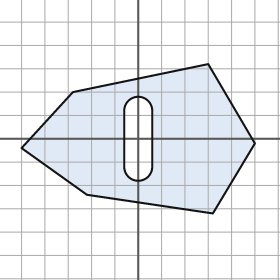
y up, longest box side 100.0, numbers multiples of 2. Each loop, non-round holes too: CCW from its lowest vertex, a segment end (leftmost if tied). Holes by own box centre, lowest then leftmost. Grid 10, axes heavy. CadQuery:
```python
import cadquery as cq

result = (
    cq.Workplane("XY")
    .moveTo(32.0, -32.0)
    .lineTo(50.0, -2.0)
    .lineTo(30.0, 32.0)
    .lineTo(-28.0, 20.0)
    .lineTo(-50.0, -4.0)
    .lineTo(-22.0, -24.0)
    .close()
    .moveTo(-6.0, -12.0)
    .threePointArc((0.0, -18.0), (6.0, -12.0))
    .lineTo(6.0, 12.0)
    .threePointArc((0.0, 18.0), (-6.0, 12.0))
    .close()
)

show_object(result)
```